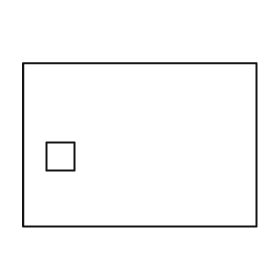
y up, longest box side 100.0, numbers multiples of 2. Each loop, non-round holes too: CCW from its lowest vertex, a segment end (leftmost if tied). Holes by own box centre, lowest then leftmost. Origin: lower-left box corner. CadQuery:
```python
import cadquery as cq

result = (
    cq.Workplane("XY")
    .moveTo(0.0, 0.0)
    .lineTo(100.0, 0.0)
    .lineTo(100.0, 70.0)
    .lineTo(0.0, 70.0)
    .close()
    .moveTo(10.0, 24.0)
    .lineTo(22.0, 24.0)
    .lineTo(22.0, 36.0)
    .lineTo(10.0, 36.0)
    .close()
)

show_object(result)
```